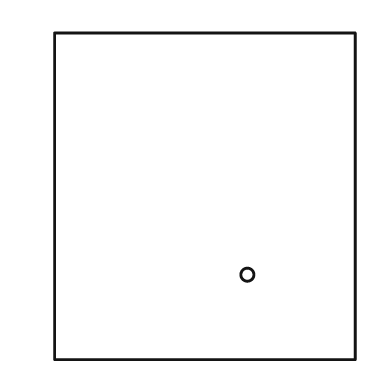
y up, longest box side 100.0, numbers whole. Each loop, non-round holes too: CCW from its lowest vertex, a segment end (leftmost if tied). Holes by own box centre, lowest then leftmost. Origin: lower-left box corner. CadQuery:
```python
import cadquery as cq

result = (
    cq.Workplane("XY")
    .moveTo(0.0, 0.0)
    .lineTo(92.0, 0.0)
    .lineTo(92.0, 100.0)
    .lineTo(0.0, 100.0)
    .close()
    .moveTo(59.0, 26.0)
    .circle(2.0)
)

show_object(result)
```